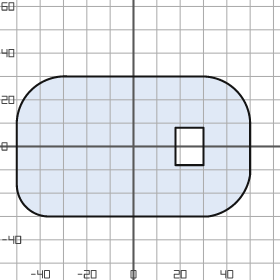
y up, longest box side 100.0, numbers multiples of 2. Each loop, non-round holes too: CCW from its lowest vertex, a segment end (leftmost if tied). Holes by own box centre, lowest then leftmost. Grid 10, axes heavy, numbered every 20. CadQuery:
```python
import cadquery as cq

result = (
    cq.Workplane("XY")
    .moveTo(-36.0, -30.0)
    .lineTo(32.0, -30.0)
    .threePointArc((44.0, -24.0), (50.0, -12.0))
    .lineTo(50.0, 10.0)
    .threePointArc((44.0, 24.0), (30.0, 30.0))
    .lineTo(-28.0, 30.0)
    .threePointArc((-44.0, 24.0), (-50.0, 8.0))
    .lineTo(-50.0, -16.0)
    .threePointArc((-46.0, -26.0), (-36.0, -30.0))
    .close()
    .moveTo(18.0, -8.0)
    .lineTo(30.0, -8.0)
    .lineTo(30.0, 8.0)
    .lineTo(18.0, 8.0)
    .close()
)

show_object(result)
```